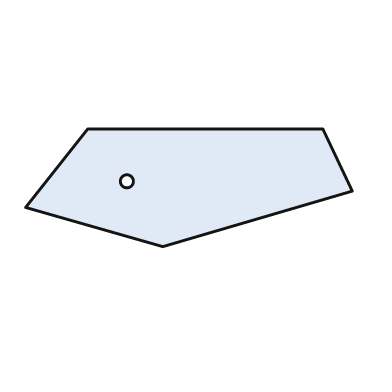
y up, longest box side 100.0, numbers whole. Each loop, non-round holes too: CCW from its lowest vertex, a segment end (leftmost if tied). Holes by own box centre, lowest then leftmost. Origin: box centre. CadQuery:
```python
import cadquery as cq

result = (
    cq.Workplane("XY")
    .moveTo(-8.0, -18.0)
    .lineTo(50.0, -1.0)
    .lineTo(41.0, 18.0)
    .lineTo(-31.0, 18.0)
    .lineTo(-50.0, -6.0)
    .close()
    .moveTo(-19.0, 2.0)
    .circle(2.0)
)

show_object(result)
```